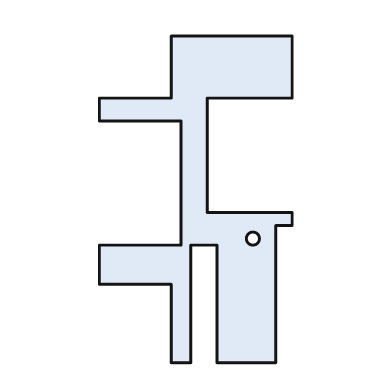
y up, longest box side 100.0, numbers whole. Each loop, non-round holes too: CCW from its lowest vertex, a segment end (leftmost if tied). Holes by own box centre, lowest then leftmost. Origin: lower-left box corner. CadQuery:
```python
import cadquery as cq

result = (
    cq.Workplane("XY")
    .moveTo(22.0, 0.0)
    .lineTo(28.0, 0.0)
    .lineTo(28.0, 36.0)
    .lineTo(36.0, 36.0)
    .lineTo(36.0, 0.0)
    .lineTo(54.0, 0.0)
    .lineTo(54.0, 42.0)
    .lineTo(59.0, 42.0)
    .lineTo(59.0, 46.0)
    .lineTo(33.0, 46.0)
    .lineTo(33.0, 81.0)
    .lineTo(59.0, 81.0)
    .lineTo(59.0, 100.0)
    .lineTo(22.0, 100.0)
    .lineTo(22.0, 81.0)
    .lineTo(0.0, 81.0)
    .lineTo(0.0, 74.0)
    .lineTo(25.0, 74.0)
    .lineTo(25.0, 36.0)
    .lineTo(0.0, 36.0)
    .lineTo(0.0, 24.0)
    .lineTo(22.0, 24.0)
    .close()
    .moveTo(47.0, 38.0)
    .circle(2.0)
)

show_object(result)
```